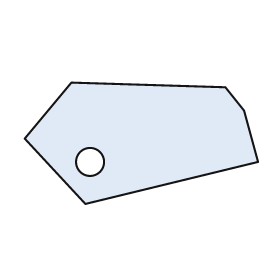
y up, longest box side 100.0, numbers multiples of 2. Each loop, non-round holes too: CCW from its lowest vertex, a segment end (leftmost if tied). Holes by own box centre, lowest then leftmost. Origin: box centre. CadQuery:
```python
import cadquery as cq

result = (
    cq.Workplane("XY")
    .moveTo(-24.0, -26.0)
    .lineTo(50.0, -8.0)
    .lineTo(44.0, 14.0)
    .lineTo(36.0, 24.0)
    .lineTo(-30.0, 26.0)
    .lineTo(-50.0, 2.0)
    .close()
    .moveTo(-22.0, -8.0)
    .circle(6.0)
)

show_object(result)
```